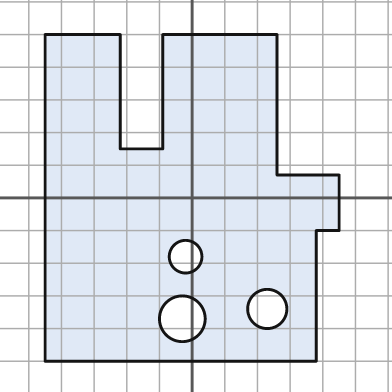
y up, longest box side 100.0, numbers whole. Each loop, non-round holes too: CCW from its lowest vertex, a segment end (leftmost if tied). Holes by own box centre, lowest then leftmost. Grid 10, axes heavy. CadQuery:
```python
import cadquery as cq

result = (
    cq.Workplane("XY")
    .moveTo(-45.0, -50.0)
    .lineTo(38.0, -50.0)
    .lineTo(38.0, -10.0)
    .lineTo(45.0, -10.0)
    .lineTo(45.0, 7.0)
    .lineTo(26.0, 7.0)
    .lineTo(26.0, 50.0)
    .lineTo(-9.0, 50.0)
    .lineTo(-9.0, 15.0)
    .lineTo(-22.0, 15.0)
    .lineTo(-22.0, 50.0)
    .lineTo(-45.0, 50.0)
    .close()
    .moveTo(-3.0, -37.0)
    .circle(7.0)
    .moveTo(23.0, -34.0)
    .circle(6.0)
    .moveTo(-2.0, -18.0)
    .circle(5.0)
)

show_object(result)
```